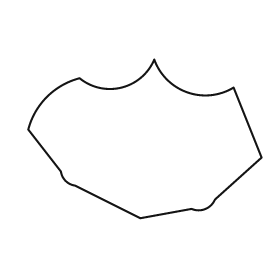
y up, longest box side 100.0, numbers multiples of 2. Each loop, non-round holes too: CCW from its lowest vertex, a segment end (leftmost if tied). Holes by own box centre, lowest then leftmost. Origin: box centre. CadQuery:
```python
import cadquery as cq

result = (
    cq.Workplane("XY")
    .moveTo(-2.0, -34.0)
    .lineTo(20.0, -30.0)
    .threePointArc((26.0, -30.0), (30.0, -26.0))
    .lineTo(50.0, -8.0)
    .lineTo(38.0, 22.0)
    .threePointArc((18.0, 20.0), (4.0, 34.0))
    .threePointArc((-10.0, 22.0), (-28.0, 26.0))
    .threePointArc((-42.0, 18.0), (-50.0, 4.0))
    .lineTo(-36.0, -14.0)
    .threePointArc((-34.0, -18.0), (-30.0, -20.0))
    .close()
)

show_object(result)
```